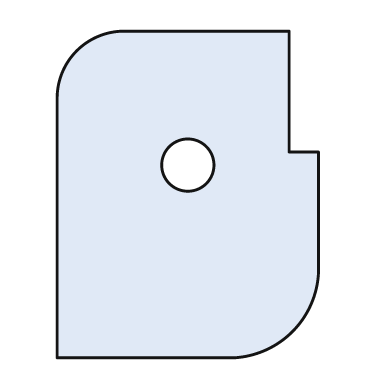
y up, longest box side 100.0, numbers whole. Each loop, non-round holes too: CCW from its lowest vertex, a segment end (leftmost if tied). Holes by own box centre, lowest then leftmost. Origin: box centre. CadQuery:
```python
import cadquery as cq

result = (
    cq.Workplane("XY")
    .moveTo(-40.0, -50.0)
    .lineTo(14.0, -50.0)
    .threePointArc((32.0, -42.0), (40.0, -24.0))
    .lineTo(40.0, 13.0)
    .lineTo(31.0, 13.0)
    .lineTo(31.0, 50.0)
    .lineTo(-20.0, 50.0)
    .threePointArc((-34.0, 44.0), (-40.0, 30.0))
    .close()
    .moveTo(0.0, 9.0)
    .circle(8.0)
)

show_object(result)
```